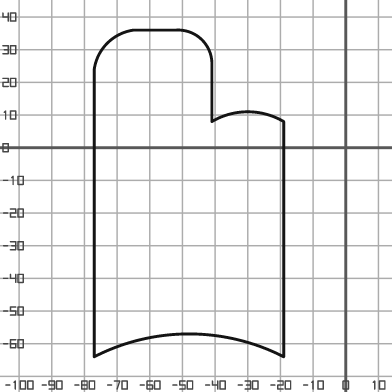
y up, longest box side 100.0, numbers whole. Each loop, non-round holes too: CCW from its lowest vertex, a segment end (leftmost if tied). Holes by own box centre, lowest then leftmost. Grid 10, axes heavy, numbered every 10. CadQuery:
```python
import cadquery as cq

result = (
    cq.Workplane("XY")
    .moveTo(-77.0, -64.0)
    .threePointArc((-48.0, -57.0), (-19.0, -64.0))
    .lineTo(-19.0, 8.0)
    .threePointArc((-30.0, 11.0), (-41.0, 8.0))
    .lineTo(-41.0, 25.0)
    .threePointArc((-44.0, 33.0), (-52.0, 36.0))
    .lineTo(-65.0, 36.0)
    .threePointArc((-73.0, 32.0), (-77.0, 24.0))
    .close()
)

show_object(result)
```